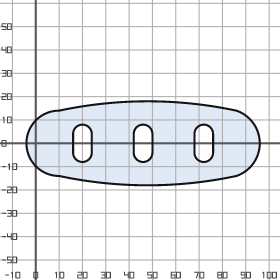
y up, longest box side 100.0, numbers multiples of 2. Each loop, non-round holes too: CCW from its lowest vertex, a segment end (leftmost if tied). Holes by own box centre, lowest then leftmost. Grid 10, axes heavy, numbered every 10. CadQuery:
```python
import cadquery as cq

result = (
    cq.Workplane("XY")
    .moveTo(10.0, -14.0)
    .threePointArc((48.0, -18.0), (86.0, -14.0))
    .threePointArc((96.0, 0.0), (86.0, 14.0))
    .threePointArc((48.0, 18.0), (10.0, 14.0))
    .threePointArc((-4.0, 0.0), (10.0, -14.0))
    .close()
    .moveTo(16.0, -4.0)
    .threePointArc((20.0, -8.0), (24.0, -4.0))
    .lineTo(24.0, 4.0)
    .threePointArc((20.0, 8.0), (16.0, 4.0))
    .close()
    .moveTo(42.0, -4.0)
    .threePointArc((46.0, -8.0), (50.0, -4.0))
    .lineTo(50.0, 4.0)
    .threePointArc((46.0, 8.0), (42.0, 4.0))
    .close()
    .moveTo(68.0, -4.0)
    .threePointArc((72.0, -8.0), (76.0, -4.0))
    .lineTo(76.0, 4.0)
    .threePointArc((72.0, 8.0), (68.0, 4.0))
    .close()
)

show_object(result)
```